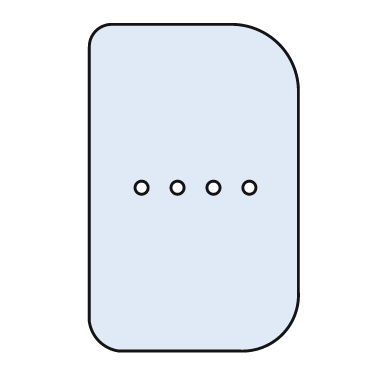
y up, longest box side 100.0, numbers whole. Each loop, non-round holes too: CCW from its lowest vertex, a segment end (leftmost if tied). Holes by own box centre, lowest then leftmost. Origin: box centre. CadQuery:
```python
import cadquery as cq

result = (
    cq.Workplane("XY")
    .moveTo(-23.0, -50.0)
    .lineTo(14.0, -50.0)
    .threePointArc((27.0, -45.0), (32.0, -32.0))
    .lineTo(32.0, 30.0)
    .threePointArc((26.0, 44.0), (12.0, 50.0))
    .lineTo(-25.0, 50.0)
    .threePointArc((-30.0, 48.0), (-32.0, 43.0))
    .lineTo(-32.0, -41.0)
    .threePointArc((-29.0, -47.0), (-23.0, -50.0))
    .close()
    .moveTo(-16.0, 0.0)
    .circle(2.0)
    .moveTo(-5.0, 0.0)
    .circle(2.0)
    .moveTo(6.0, 0.0)
    .circle(2.0)
    .moveTo(17.0, 0.0)
    .circle(2.0)
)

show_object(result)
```